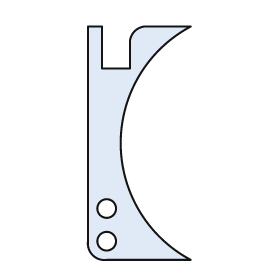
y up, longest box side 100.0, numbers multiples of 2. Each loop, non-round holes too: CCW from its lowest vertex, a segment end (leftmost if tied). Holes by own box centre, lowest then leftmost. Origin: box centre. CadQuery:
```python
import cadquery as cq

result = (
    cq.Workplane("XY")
    .moveTo(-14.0, -50.0)
    .lineTo(22.0, -50.0)
    .threePointArc((-8.0, 0.0), (22.0, 50.0))
    .lineTo(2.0, 50.0)
    .threePointArc((-2.0, 48.0), (-4.0, 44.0))
    .lineTo(-4.0, 32.0)
    .lineTo(-16.0, 32.0)
    .lineTo(-16.0, 50.0)
    .lineTo(-22.0, 50.0)
    .lineTo(-22.0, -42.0)
    .threePointArc((-20.0, -48.0), (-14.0, -50.0))
    .close()
    .moveTo(-14.0, -42.0)
    .circle(4.0)
    .moveTo(-14.0, -28.0)
    .circle(4.0)
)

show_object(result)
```